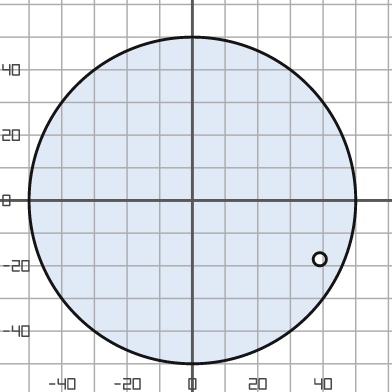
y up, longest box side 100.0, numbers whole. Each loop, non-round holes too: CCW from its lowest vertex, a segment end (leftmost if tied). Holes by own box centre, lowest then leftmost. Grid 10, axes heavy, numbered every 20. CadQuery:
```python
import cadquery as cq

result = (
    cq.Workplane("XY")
    .moveTo(0.0, 0.0)
    .circle(50.0)
    .moveTo(39.0, -18.0)
    .circle(2.0)
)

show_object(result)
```